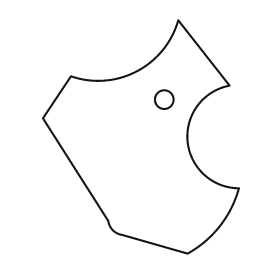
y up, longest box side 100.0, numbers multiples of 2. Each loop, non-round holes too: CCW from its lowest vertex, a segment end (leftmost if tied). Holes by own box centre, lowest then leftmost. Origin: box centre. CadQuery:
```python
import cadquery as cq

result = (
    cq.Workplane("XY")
    .moveTo(20.0, -50.0)
    .threePointArc((34.0, -38.0), (42.0, -22.0))
    .threePointArc((20.0, -2.0), (38.0, 22.0))
    .lineTo(16.0, 50.0)
    .threePointArc((-2.0, 28.0), (-30.0, 26.0))
    .lineTo(-42.0, 8.0)
    .lineTo(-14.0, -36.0)
    .threePointArc((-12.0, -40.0), (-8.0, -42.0))
    .close()
    .moveTo(10.0, 16.0)
    .circle(4.0)
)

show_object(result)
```